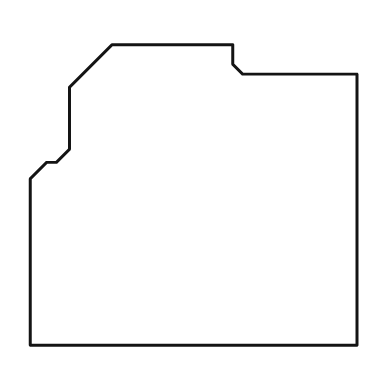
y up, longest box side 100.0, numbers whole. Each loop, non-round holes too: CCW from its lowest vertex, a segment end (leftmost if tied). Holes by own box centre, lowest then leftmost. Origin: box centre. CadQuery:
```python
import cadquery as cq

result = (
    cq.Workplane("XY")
    .moveTo(-50.0, -46.0)
    .lineTo(50.0, -46.0)
    .lineTo(50.0, 37.0)
    .lineTo(15.0, 37.0)
    .lineTo(12.0, 40.0)
    .lineTo(12.0, 46.0)
    .lineTo(-25.0, 46.0)
    .lineTo(-38.0, 33.0)
    .lineTo(-38.0, 14.0)
    .lineTo(-42.0, 10.0)
    .lineTo(-45.0, 10.0)
    .lineTo(-50.0, 5.0)
    .close()
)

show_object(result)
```